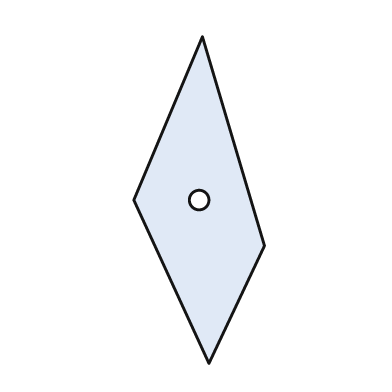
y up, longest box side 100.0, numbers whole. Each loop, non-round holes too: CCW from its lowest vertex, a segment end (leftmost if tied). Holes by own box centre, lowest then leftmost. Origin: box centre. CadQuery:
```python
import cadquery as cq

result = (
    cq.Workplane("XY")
    .moveTo(3.0, -50.0)
    .lineTo(20.0, -14.0)
    .lineTo(1.0, 50.0)
    .lineTo(-20.0, 0.0)
    .close()
    .moveTo(0.0, 0.0)
    .circle(3.0)
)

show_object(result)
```